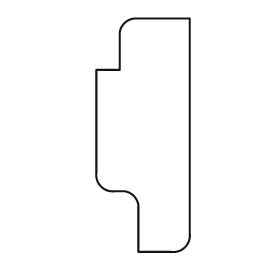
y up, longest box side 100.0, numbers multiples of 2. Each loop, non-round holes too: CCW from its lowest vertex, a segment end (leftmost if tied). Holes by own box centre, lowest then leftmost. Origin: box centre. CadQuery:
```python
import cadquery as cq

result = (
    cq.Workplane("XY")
    .moveTo(-2.0, -50.0)
    .lineTo(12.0, -50.0)
    .threePointArc((18.0, -48.0), (20.0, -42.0))
    .lineTo(20.0, 50.0)
    .lineTo(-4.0, 50.0)
    .threePointArc((-8.0, 48.0), (-10.0, 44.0))
    .lineTo(-10.0, 28.0)
    .lineTo(-20.0, 28.0)
    .lineTo(-20.0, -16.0)
    .threePointArc((-18.0, -22.0), (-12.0, -24.0))
    .lineTo(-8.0, -24.0)
    .threePointArc((-4.0, -26.0), (-2.0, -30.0))
    .close()
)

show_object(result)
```